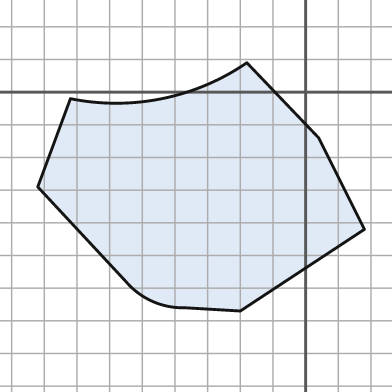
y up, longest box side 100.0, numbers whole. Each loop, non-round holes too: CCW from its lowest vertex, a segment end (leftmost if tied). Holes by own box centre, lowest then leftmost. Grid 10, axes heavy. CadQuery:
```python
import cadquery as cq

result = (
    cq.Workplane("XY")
    .moveTo(-20.0, -67.0)
    .lineTo(18.0, -42.0)
    .lineTo(4.0, -14.0)
    .lineTo(-18.0, 9.0)
    .threePointArc((-44.0, -2.0), (-72.0, -2.0))
    .lineTo(-82.0, -29.0)
    .lineTo(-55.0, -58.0)
    .threePointArc((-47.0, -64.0), (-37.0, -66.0))
    .close()
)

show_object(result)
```